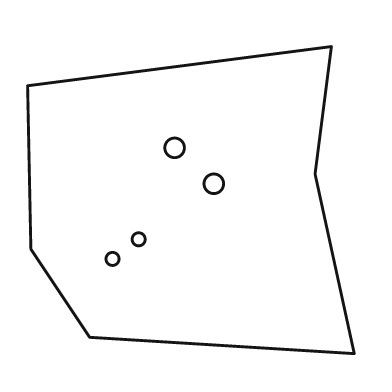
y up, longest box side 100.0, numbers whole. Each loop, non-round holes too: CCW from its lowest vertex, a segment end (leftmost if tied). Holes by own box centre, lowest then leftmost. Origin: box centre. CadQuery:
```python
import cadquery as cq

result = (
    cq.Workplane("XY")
    .moveTo(50.0, -47.0)
    .lineTo(38.0, 8.0)
    .lineTo(43.0, 47.0)
    .lineTo(-50.0, 35.0)
    .lineTo(-49.0, -15.0)
    .lineTo(-31.0, -42.0)
    .close()
    .moveTo(-24.0, -18.0)
    .circle(2.0)
    .moveTo(-16.0, -12.0)
    .circle(2.0)
    .moveTo(7.0, 5.0)
    .circle(3.0)
    .moveTo(-5.0, 16.0)
    .circle(3.0)
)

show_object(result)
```